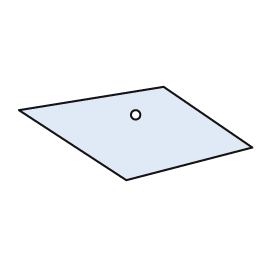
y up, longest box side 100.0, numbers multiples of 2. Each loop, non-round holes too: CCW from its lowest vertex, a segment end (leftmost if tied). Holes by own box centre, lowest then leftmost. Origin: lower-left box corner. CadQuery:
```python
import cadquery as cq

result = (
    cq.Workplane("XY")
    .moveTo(46.0, 0.0)
    .lineTo(100.0, 14.0)
    .lineTo(62.0, 40.0)
    .lineTo(0.0, 30.0)
    .close()
    .moveTo(50.0, 28.0)
    .circle(2.0)
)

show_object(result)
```